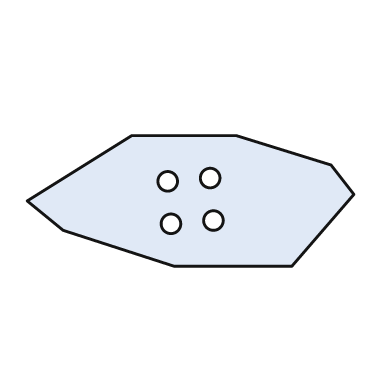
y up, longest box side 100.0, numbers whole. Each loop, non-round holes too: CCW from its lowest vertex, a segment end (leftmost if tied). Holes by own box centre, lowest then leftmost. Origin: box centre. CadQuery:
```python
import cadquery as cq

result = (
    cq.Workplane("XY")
    .moveTo(-5.0, -20.0)
    .lineTo(31.0, -20.0)
    .lineTo(50.0, 2.0)
    .lineTo(43.0, 11.0)
    .lineTo(14.0, 20.0)
    .lineTo(-18.0, 20.0)
    .lineTo(-50.0, 0.0)
    .lineTo(-39.0, -9.0)
    .close()
    .moveTo(-6.0, -7.0)
    .circle(3.0)
    .moveTo(7.0, -6.0)
    .circle(3.0)
    .moveTo(-7.0, 6.0)
    .circle(3.0)
    .moveTo(6.0, 7.0)
    .circle(3.0)
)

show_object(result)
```